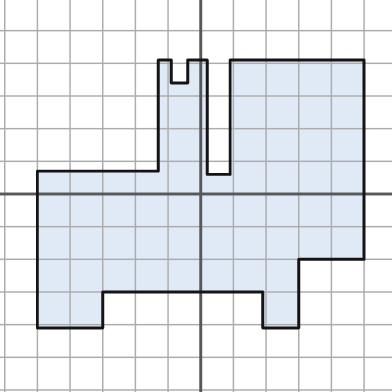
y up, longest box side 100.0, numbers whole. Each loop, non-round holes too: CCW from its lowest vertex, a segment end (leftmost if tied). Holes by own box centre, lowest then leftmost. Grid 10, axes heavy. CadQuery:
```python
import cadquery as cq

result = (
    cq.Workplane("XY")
    .moveTo(-50.0, -41.0)
    .lineTo(-30.0, -41.0)
    .lineTo(-30.0, -30.0)
    .lineTo(19.0, -30.0)
    .lineTo(19.0, -41.0)
    .lineTo(30.0, -41.0)
    .lineTo(30.0, -20.0)
    .lineTo(50.0, -20.0)
    .lineTo(50.0, 41.0)
    .lineTo(9.0, 41.0)
    .lineTo(9.0, 6.0)
    .lineTo(2.0, 6.0)
    .lineTo(2.0, 41.0)
    .lineTo(-4.0, 41.0)
    .lineTo(-4.0, 34.0)
    .lineTo(-9.0, 34.0)
    .lineTo(-9.0, 41.0)
    .lineTo(-13.0, 41.0)
    .lineTo(-13.0, 7.0)
    .lineTo(-50.0, 7.0)
    .close()
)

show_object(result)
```